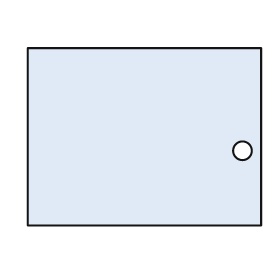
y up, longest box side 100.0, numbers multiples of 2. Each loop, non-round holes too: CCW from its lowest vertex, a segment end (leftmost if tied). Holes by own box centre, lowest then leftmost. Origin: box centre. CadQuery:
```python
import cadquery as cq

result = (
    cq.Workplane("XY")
    .moveTo(-50.0, -38.0)
    .lineTo(50.0, -38.0)
    .lineTo(50.0, 38.0)
    .lineTo(-50.0, 38.0)
    .close()
    .moveTo(42.0, -6.0)
    .circle(4.0)
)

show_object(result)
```